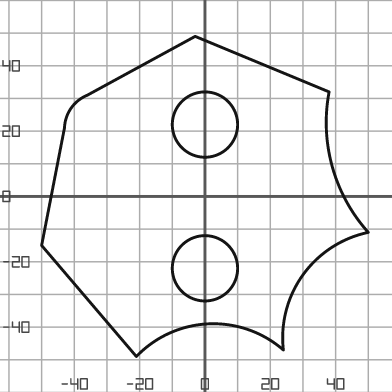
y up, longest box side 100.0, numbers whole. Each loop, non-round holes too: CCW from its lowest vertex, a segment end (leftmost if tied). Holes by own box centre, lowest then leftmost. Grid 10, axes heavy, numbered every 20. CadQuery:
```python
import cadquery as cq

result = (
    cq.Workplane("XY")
    .moveTo(-21.0, -49.0)
    .threePointArc((1.0, -39.0), (24.0, -47.0))
    .threePointArc((30.0, -24.0), (50.0, -11.0))
    .threePointArc((39.0, 9.0), (38.0, 32.0))
    .lineTo(-3.0, 49.0)
    .lineTo(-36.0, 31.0)
    .threePointArc((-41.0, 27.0), (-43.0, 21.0))
    .lineTo(-50.0, -15.0)
    .close()
    .moveTo(0.0, -22.0)
    .circle(10.0)
    .moveTo(0.0, 22.0)
    .circle(10.0)
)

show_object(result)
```